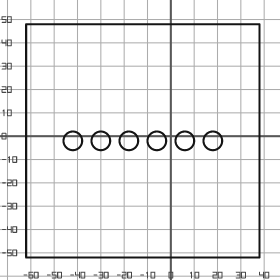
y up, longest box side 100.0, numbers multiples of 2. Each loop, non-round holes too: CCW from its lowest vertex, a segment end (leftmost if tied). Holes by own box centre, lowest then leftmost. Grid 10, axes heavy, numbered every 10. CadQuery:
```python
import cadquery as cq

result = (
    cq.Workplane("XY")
    .moveTo(-62.0, -52.0)
    .lineTo(38.0, -52.0)
    .lineTo(38.0, 48.0)
    .lineTo(-62.0, 48.0)
    .close()
    .moveTo(-42.0, -2.0)
    .circle(4.0)
    .moveTo(-30.0, -2.0)
    .circle(4.0)
    .moveTo(-18.0, -2.0)
    .circle(4.0)
    .moveTo(-6.0, -2.0)
    .circle(4.0)
    .moveTo(6.0, -2.0)
    .circle(4.0)
    .moveTo(18.0, -2.0)
    .circle(4.0)
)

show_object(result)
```